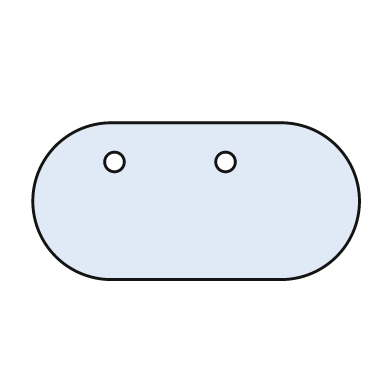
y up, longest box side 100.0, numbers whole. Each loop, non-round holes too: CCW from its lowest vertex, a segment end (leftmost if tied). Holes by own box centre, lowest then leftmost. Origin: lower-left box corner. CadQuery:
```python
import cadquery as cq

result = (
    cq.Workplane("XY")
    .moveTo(24.0, 0.0)
    .lineTo(76.0, 0.0)
    .threePointArc((100.0, 24.0), (76.0, 48.0))
    .lineTo(24.0, 48.0)
    .threePointArc((0.0, 24.0), (24.0, 0.0))
    .close()
    .moveTo(25.0, 36.0)
    .circle(3.0)
    .moveTo(59.0, 36.0)
    .circle(3.0)
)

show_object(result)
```